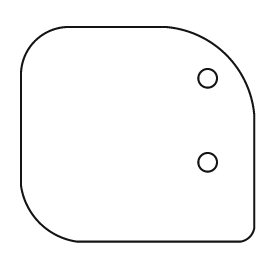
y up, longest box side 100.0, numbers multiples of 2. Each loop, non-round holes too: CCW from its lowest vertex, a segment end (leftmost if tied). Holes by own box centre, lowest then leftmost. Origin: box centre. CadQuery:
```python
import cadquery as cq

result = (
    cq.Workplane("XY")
    .moveTo(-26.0, -46.0)
    .lineTo(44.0, -46.0)
    .threePointArc((48.0, -44.0), (50.0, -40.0))
    .lineTo(50.0, 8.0)
    .threePointArc((38.0, 34.0), (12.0, 46.0))
    .lineTo(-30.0, 46.0)
    .threePointArc((-44.0, 40.0), (-50.0, 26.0))
    .lineTo(-50.0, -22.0)
    .threePointArc((-42.0, -38.0), (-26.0, -46.0))
    .close()
    .moveTo(30.0, -12.0)
    .circle(4.0)
    .moveTo(30.0, 24.0)
    .circle(4.0)
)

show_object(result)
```